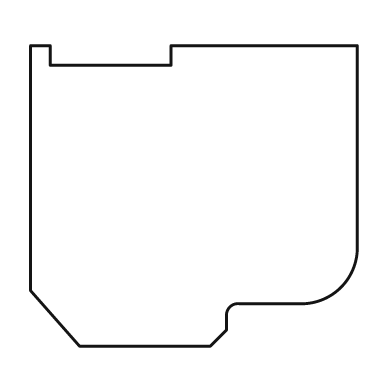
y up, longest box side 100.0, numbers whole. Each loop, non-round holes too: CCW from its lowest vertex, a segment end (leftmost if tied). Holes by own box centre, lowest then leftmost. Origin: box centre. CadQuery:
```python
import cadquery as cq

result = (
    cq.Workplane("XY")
    .moveTo(-35.0, -46.0)
    .lineTo(5.0, -46.0)
    .lineTo(10.0, -41.0)
    .lineTo(10.0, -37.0)
    .threePointArc((11.0, -34.0), (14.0, -33.0))
    .lineTo(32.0, -33.0)
    .threePointArc((45.0, -28.0), (50.0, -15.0))
    .lineTo(50.0, 46.0)
    .lineTo(-7.0, 46.0)
    .lineTo(-7.0, 40.0)
    .lineTo(-44.0, 40.0)
    .lineTo(-44.0, 46.0)
    .lineTo(-50.0, 46.0)
    .lineTo(-50.0, -29.0)
    .close()
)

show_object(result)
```